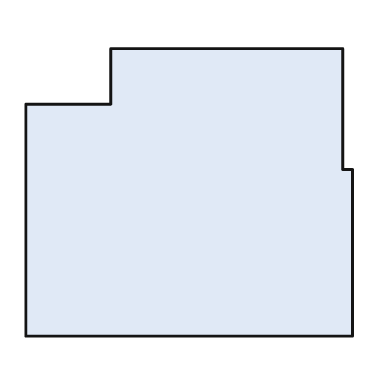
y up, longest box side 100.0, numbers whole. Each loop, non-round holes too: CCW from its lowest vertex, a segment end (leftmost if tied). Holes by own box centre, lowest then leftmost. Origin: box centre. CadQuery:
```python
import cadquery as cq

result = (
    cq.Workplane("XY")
    .moveTo(-50.0, -44.0)
    .lineTo(50.0, -44.0)
    .lineTo(50.0, 7.0)
    .lineTo(47.0, 7.0)
    .lineTo(47.0, 44.0)
    .lineTo(-24.0, 44.0)
    .lineTo(-24.0, 27.0)
    .lineTo(-50.0, 27.0)
    .close()
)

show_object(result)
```